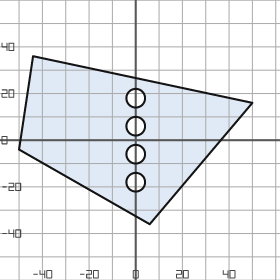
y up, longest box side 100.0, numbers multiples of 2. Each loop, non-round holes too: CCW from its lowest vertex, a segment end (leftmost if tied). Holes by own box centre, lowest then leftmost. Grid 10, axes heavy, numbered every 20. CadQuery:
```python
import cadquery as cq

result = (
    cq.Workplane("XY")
    .moveTo(6.0, -36.0)
    .lineTo(50.0, 16.0)
    .lineTo(-44.0, 36.0)
    .lineTo(-50.0, -4.0)
    .close()
    .moveTo(0.0, -18.0)
    .circle(4.0)
    .moveTo(0.0, -6.0)
    .circle(4.0)
    .moveTo(0.0, 6.0)
    .circle(4.0)
    .moveTo(0.0, 18.0)
    .circle(4.0)
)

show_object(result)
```